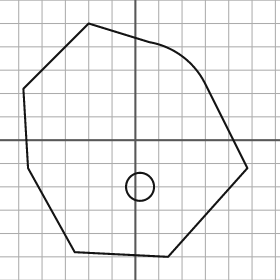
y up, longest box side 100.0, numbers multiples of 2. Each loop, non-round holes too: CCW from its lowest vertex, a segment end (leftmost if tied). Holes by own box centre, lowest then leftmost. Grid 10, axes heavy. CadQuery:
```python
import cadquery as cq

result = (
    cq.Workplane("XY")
    .moveTo(14.0, -50.0)
    .lineTo(48.0, -12.0)
    .lineTo(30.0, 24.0)
    .threePointArc((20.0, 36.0), (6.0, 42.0))
    .lineTo(-20.0, 50.0)
    .lineTo(-48.0, 22.0)
    .lineTo(-46.0, -12.0)
    .lineTo(-26.0, -48.0)
    .close()
    .moveTo(2.0, -20.0)
    .circle(6.0)
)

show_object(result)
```